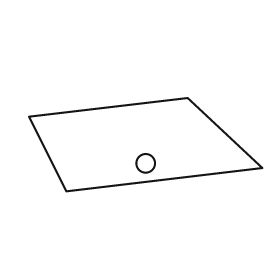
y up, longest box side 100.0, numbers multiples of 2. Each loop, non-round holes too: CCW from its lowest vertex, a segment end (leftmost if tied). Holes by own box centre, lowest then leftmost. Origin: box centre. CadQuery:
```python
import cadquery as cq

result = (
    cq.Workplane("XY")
    .moveTo(-34.0, -20.0)
    .lineTo(50.0, -10.0)
    .lineTo(18.0, 20.0)
    .lineTo(-50.0, 12.0)
    .close()
    .moveTo(0.0, -8.0)
    .circle(4.0)
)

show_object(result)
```